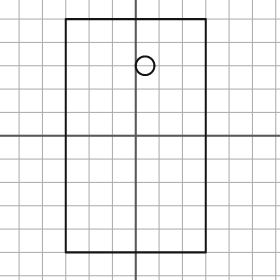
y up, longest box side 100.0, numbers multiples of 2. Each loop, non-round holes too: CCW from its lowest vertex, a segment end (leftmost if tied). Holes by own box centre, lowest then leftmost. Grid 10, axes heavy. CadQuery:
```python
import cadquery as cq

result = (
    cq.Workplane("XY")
    .moveTo(-30.0, -50.0)
    .lineTo(30.0, -50.0)
    .lineTo(30.0, 50.0)
    .lineTo(-30.0, 50.0)
    .close()
    .moveTo(4.0, 30.0)
    .circle(4.0)
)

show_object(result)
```